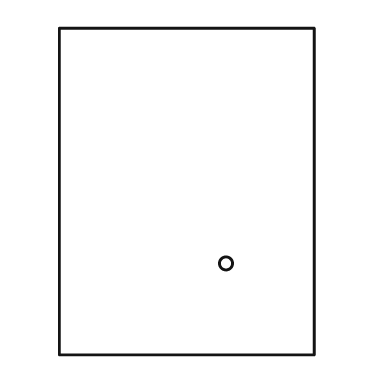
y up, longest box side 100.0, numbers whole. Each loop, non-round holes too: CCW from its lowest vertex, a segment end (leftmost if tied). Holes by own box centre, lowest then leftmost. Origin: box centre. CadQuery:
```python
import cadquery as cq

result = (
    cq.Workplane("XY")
    .moveTo(-39.0, -50.0)
    .lineTo(39.0, -50.0)
    .lineTo(39.0, 50.0)
    .lineTo(-39.0, 50.0)
    .close()
    .moveTo(12.0, -22.0)
    .circle(2.0)
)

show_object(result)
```